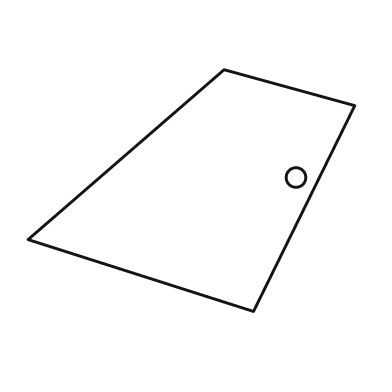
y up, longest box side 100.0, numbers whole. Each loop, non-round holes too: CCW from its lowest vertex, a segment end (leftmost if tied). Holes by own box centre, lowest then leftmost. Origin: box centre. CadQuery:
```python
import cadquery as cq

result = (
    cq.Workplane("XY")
    .moveTo(19.0, -37.0)
    .lineTo(50.0, 26.0)
    .lineTo(10.0, 37.0)
    .lineTo(-50.0, -15.0)
    .close()
    .moveTo(32.0, 4.0)
    .circle(3.0)
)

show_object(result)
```